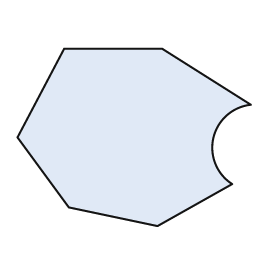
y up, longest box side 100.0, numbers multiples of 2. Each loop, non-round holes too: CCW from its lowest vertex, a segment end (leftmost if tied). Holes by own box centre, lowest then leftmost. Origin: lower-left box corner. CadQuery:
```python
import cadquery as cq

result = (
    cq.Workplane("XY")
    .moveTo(60.0, 0.0)
    .lineTo(92.0, 18.0)
    .threePointArc((84.0, 38.0), (100.0, 52.0))
    .lineTo(62.0, 76.0)
    .lineTo(20.0, 76.0)
    .lineTo(0.0, 38.0)
    .lineTo(22.0, 8.0)
    .close()
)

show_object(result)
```